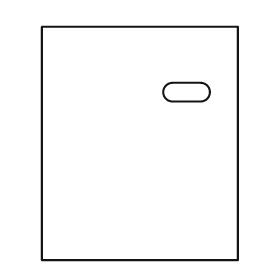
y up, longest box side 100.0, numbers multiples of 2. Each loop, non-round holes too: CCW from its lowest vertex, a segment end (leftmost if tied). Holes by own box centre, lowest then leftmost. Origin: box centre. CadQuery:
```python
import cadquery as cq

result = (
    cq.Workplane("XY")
    .moveTo(-42.0, -50.0)
    .lineTo(42.0, -50.0)
    .lineTo(42.0, 50.0)
    .lineTo(-42.0, 50.0)
    .close()
    .moveTo(14.0, 18.0)
    .lineTo(26.0, 18.0)
    .threePointArc((30.0, 22.0), (26.0, 26.0))
    .lineTo(14.0, 26.0)
    .threePointArc((10.0, 22.0), (14.0, 18.0))
    .close()
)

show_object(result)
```